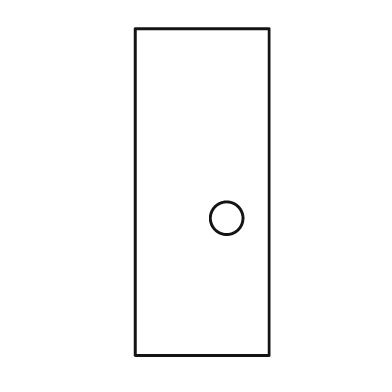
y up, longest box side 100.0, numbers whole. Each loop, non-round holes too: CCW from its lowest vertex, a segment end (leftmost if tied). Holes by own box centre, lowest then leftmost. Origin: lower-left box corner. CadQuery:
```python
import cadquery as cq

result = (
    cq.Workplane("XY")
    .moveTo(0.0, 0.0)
    .lineTo(41.0, 0.0)
    .lineTo(41.0, 100.0)
    .lineTo(0.0, 100.0)
    .close()
    .moveTo(28.0, 42.0)
    .circle(5.0)
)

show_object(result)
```